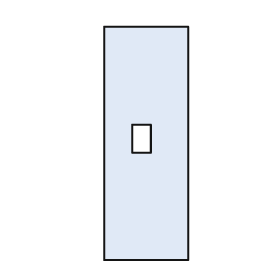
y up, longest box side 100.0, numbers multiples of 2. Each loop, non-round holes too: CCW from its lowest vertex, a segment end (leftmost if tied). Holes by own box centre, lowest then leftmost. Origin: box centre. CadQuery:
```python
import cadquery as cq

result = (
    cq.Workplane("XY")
    .moveTo(-18.0, -50.0)
    .lineTo(18.0, -50.0)
    .lineTo(18.0, 50.0)
    .lineTo(-18.0, 50.0)
    .close()
    .moveTo(-6.0, -4.0)
    .lineTo(2.0, -4.0)
    .lineTo(2.0, 8.0)
    .lineTo(-6.0, 8.0)
    .close()
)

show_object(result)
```